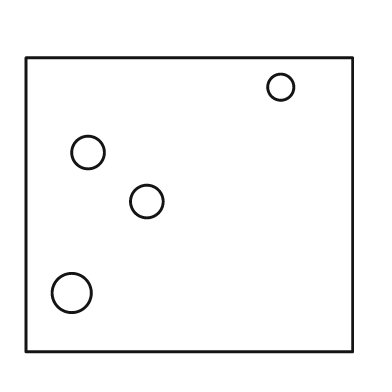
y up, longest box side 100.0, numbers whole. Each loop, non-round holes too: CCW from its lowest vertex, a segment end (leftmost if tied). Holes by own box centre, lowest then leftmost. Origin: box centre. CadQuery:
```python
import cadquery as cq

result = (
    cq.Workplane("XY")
    .moveTo(-50.0, -45.0)
    .lineTo(50.0, -45.0)
    .lineTo(50.0, 45.0)
    .lineTo(-50.0, 45.0)
    .close()
    .moveTo(-36.0, -27.0)
    .circle(6.0)
    .moveTo(-13.0, 1.0)
    .circle(5.0)
    .moveTo(-31.0, 16.0)
    .circle(5.0)
    .moveTo(28.0, 36.0)
    .circle(4.0)
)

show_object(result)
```